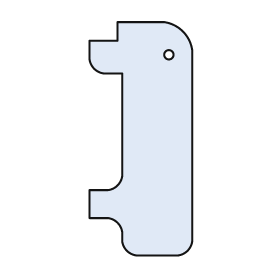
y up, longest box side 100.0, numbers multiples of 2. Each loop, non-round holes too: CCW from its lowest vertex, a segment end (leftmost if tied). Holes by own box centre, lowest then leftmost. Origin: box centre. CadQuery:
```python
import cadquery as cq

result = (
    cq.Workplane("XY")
    .moveTo(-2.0, -50.0)
    .lineTo(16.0, -50.0)
    .threePointArc((20.0, -48.0), (22.0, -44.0))
    .lineTo(22.0, 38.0)
    .threePointArc((18.0, 46.0), (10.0, 50.0))
    .lineTo(-10.0, 50.0)
    .lineTo(-10.0, 42.0)
    .lineTo(-22.0, 42.0)
    .lineTo(-22.0, 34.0)
    .threePointArc((-20.0, 30.0), (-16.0, 28.0))
    .lineTo(-8.0, 28.0)
    .lineTo(-8.0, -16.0)
    .threePointArc((-10.0, -20.0), (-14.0, -22.0))
    .lineTo(-22.0, -22.0)
    .lineTo(-22.0, -34.0)
    .lineTo(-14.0, -34.0)
    .threePointArc((-10.0, -36.0), (-8.0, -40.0))
    .lineTo(-8.0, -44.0)
    .threePointArc((-6.0, -48.0), (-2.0, -50.0))
    .close()
    .moveTo(12.0, 36.0)
    .circle(2.0)
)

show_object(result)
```